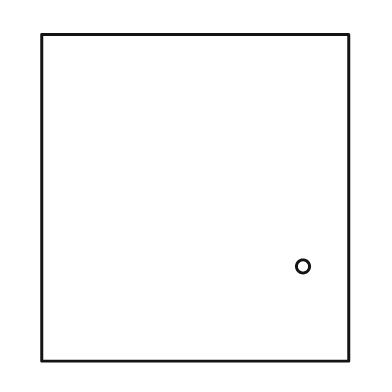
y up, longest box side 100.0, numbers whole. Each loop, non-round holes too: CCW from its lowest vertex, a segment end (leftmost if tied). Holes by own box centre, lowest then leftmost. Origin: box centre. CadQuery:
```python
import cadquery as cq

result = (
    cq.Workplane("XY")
    .moveTo(-47.0, -50.0)
    .lineTo(47.0, -50.0)
    .lineTo(47.0, 50.0)
    .lineTo(-47.0, 50.0)
    .close()
    .moveTo(33.0, -21.0)
    .circle(2.0)
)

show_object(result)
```